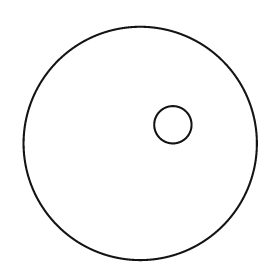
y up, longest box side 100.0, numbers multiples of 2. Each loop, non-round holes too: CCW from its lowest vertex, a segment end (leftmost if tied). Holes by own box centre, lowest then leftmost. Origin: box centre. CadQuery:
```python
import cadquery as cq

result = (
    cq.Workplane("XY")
    .moveTo(0.0, 0.0)
    .circle(50.0)
    .moveTo(14.0, 8.0)
    .circle(8.0)
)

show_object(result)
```